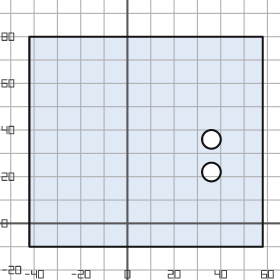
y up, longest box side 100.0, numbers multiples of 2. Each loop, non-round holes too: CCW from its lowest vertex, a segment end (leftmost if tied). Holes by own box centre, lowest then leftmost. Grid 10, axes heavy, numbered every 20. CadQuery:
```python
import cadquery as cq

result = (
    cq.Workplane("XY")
    .moveTo(-42.0, -10.0)
    .lineTo(58.0, -10.0)
    .lineTo(58.0, 80.0)
    .lineTo(-42.0, 80.0)
    .close()
    .moveTo(36.0, 22.0)
    .circle(4.0)
    .moveTo(36.0, 36.0)
    .circle(4.0)
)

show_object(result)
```